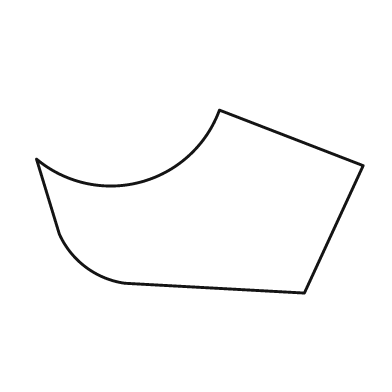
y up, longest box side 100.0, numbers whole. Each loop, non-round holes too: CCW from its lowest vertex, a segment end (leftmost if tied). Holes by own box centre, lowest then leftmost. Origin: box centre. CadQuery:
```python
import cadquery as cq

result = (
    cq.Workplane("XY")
    .moveTo(32.0, -28.0)
    .lineTo(50.0, 11.0)
    .lineTo(6.0, 28.0)
    .threePointArc((-18.0, 6.0), (-50.0, 13.0))
    .lineTo(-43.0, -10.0)
    .threePointArc((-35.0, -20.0), (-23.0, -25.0))
    .close()
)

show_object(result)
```